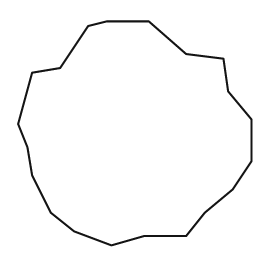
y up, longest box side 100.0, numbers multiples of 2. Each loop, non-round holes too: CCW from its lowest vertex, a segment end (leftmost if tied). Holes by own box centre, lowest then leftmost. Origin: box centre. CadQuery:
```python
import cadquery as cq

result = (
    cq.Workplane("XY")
    .moveTo(-10.0, -48.0)
    .lineTo(4.0, -44.0)
    .lineTo(22.0, -44.0)
    .lineTo(30.0, -34.0)
    .lineTo(42.0, -24.0)
    .lineTo(50.0, -12.0)
    .lineTo(50.0, 6.0)
    .lineTo(40.0, 18.0)
    .lineTo(38.0, 32.0)
    .lineTo(22.0, 34.0)
    .lineTo(6.0, 48.0)
    .lineTo(-12.0, 48.0)
    .lineTo(-20.0, 46.0)
    .lineTo(-32.0, 28.0)
    .lineTo(-44.0, 26.0)
    .lineTo(-50.0, 4.0)
    .lineTo(-46.0, -6.0)
    .lineTo(-44.0, -18.0)
    .lineTo(-36.0, -34.0)
    .lineTo(-26.0, -42.0)
    .close()
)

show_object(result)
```